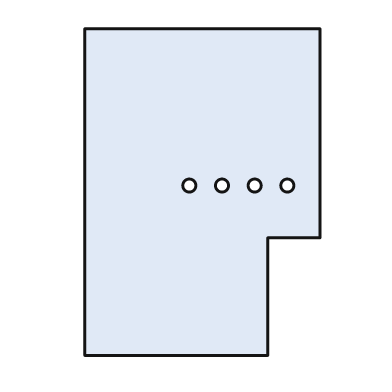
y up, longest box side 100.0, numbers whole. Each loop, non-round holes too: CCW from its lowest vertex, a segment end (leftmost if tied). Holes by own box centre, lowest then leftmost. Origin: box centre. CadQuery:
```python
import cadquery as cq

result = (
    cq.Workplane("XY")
    .moveTo(-36.0, -50.0)
    .lineTo(20.0, -50.0)
    .lineTo(20.0, -14.0)
    .lineTo(36.0, -14.0)
    .lineTo(36.0, 50.0)
    .lineTo(-36.0, 50.0)
    .close()
    .moveTo(-4.0, 2.0)
    .circle(2.0)
    .moveTo(6.0, 2.0)
    .circle(2.0)
    .moveTo(16.0, 2.0)
    .circle(2.0)
    .moveTo(26.0, 2.0)
    .circle(2.0)
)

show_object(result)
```